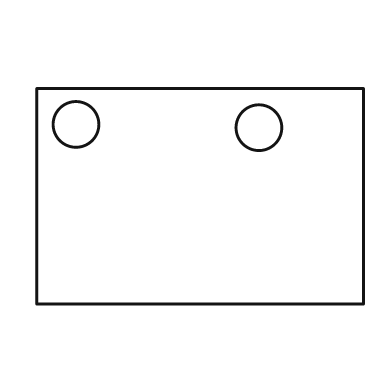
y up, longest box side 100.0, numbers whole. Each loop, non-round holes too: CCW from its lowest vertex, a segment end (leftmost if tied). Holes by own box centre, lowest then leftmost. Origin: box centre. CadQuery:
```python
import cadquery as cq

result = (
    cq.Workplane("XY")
    .moveTo(-50.0, -33.0)
    .lineTo(50.0, -33.0)
    .lineTo(50.0, 33.0)
    .lineTo(-50.0, 33.0)
    .close()
    .moveTo(18.0, 21.0)
    .circle(7.0)
    .moveTo(-38.0, 22.0)
    .circle(7.0)
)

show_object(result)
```